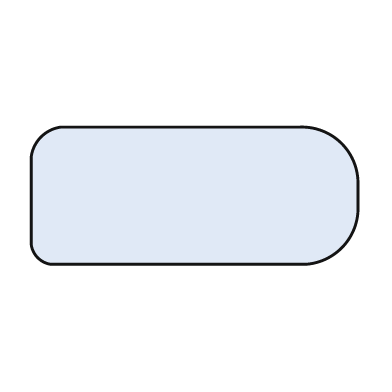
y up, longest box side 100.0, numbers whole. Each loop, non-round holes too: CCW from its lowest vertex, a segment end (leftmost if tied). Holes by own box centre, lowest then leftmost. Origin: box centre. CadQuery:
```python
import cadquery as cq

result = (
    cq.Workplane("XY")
    .moveTo(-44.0, -21.0)
    .lineTo(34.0, -21.0)
    .threePointArc((45.0, -16.0), (50.0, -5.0))
    .lineTo(50.0, 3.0)
    .threePointArc((45.0, 16.0), (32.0, 21.0))
    .lineTo(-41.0, 21.0)
    .threePointArc((-47.0, 18.0), (-50.0, 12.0))
    .lineTo(-50.0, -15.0)
    .threePointArc((-48.0, -19.0), (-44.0, -21.0))
    .close()
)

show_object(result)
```